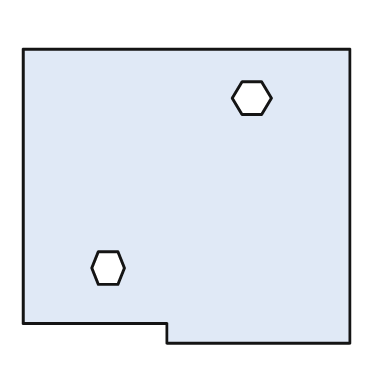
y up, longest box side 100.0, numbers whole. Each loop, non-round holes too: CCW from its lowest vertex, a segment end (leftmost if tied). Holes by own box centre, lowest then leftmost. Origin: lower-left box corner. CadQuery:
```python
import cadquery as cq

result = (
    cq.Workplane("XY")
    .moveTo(44.0, 0.0)
    .lineTo(100.0, 0.0)
    .lineTo(100.0, 90.0)
    .lineTo(0.0, 90.0)
    .lineTo(0.0, 6.0)
    .lineTo(44.0, 6.0)
    .close()
    .moveTo(23.0, 18.0)
    .lineTo(29.0, 18.0)
    .lineTo(31.0, 23.0)
    .lineTo(29.0, 28.0)
    .lineTo(23.0, 28.0)
    .lineTo(21.0, 23.0)
    .close()
    .moveTo(67.0, 70.0)
    .lineTo(73.0, 70.0)
    .lineTo(76.0, 75.0)
    .lineTo(73.0, 80.0)
    .lineTo(67.0, 80.0)
    .lineTo(64.0, 75.0)
    .close()
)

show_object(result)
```